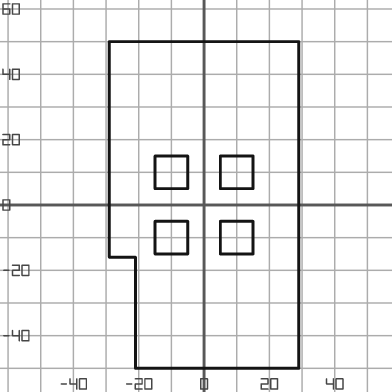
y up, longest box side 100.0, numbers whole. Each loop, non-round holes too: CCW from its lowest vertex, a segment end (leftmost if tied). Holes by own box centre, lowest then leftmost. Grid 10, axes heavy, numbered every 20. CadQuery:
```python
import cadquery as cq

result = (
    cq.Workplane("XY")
    .moveTo(-21.0, -50.0)
    .lineTo(29.0, -50.0)
    .lineTo(29.0, 50.0)
    .lineTo(-29.0, 50.0)
    .lineTo(-29.0, -16.0)
    .lineTo(-21.0, -16.0)
    .close()
    .moveTo(-15.0, -15.0)
    .lineTo(-5.0, -15.0)
    .lineTo(-5.0, -5.0)
    .lineTo(-15.0, -5.0)
    .close()
    .moveTo(5.0, -15.0)
    .lineTo(15.0, -15.0)
    .lineTo(15.0, -5.0)
    .lineTo(5.0, -5.0)
    .close()
    .moveTo(-15.0, 5.0)
    .lineTo(-5.0, 5.0)
    .lineTo(-5.0, 15.0)
    .lineTo(-15.0, 15.0)
    .close()
    .moveTo(5.0, 5.0)
    .lineTo(15.0, 5.0)
    .lineTo(15.0, 15.0)
    .lineTo(5.0, 15.0)
    .close()
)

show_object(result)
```